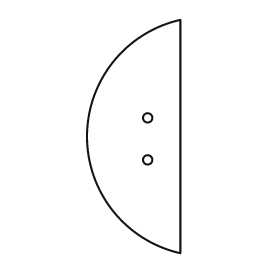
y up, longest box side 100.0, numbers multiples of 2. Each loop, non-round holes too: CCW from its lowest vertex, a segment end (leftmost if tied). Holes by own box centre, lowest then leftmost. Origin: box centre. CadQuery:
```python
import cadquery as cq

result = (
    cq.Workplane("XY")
    .moveTo(20.0, -50.0)
    .lineTo(20.0, 50.0)
    .threePointArc((-20.0, 0.0), (20.0, -50.0))
    .close()
    .moveTo(6.0, -10.0)
    .circle(2.0)
    .moveTo(6.0, 8.0)
    .circle(2.0)
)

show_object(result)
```